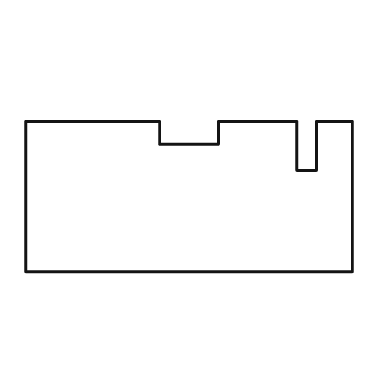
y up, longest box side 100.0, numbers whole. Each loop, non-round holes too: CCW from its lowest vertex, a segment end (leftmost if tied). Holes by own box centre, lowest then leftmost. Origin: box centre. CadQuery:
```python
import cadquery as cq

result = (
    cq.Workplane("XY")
    .moveTo(-50.0, -23.0)
    .lineTo(50.0, -23.0)
    .lineTo(50.0, 23.0)
    .lineTo(39.0, 23.0)
    .lineTo(39.0, 8.0)
    .lineTo(33.0, 8.0)
    .lineTo(33.0, 23.0)
    .lineTo(9.0, 23.0)
    .lineTo(9.0, 16.0)
    .lineTo(-9.0, 16.0)
    .lineTo(-9.0, 23.0)
    .lineTo(-50.0, 23.0)
    .close()
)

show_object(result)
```